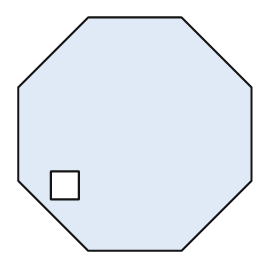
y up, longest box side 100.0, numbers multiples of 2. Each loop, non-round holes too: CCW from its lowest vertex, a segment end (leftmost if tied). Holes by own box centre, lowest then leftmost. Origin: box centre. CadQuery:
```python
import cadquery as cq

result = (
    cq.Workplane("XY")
    .moveTo(-20.0, -50.0)
    .lineTo(20.0, -50.0)
    .lineTo(50.0, -20.0)
    .lineTo(50.0, 20.0)
    .lineTo(20.0, 50.0)
    .lineTo(-20.0, 50.0)
    .lineTo(-50.0, 20.0)
    .lineTo(-50.0, -20.0)
    .close()
    .moveTo(-36.0, -28.0)
    .lineTo(-24.0, -28.0)
    .lineTo(-24.0, -16.0)
    .lineTo(-36.0, -16.0)
    .close()
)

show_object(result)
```